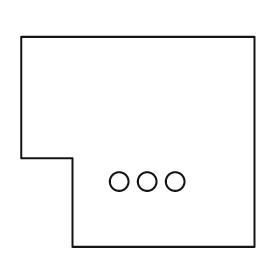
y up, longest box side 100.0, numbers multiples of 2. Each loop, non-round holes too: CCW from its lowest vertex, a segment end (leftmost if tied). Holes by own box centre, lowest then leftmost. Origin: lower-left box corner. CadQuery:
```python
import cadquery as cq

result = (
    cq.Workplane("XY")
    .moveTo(22.0, 0.0)
    .lineTo(100.0, 0.0)
    .lineTo(100.0, 90.0)
    .lineTo(0.0, 90.0)
    .lineTo(0.0, 38.0)
    .lineTo(22.0, 38.0)
    .close()
    .moveTo(42.0, 28.0)
    .circle(4.0)
    .moveTo(54.0, 28.0)
    .circle(4.0)
    .moveTo(66.0, 28.0)
    .circle(4.0)
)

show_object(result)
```